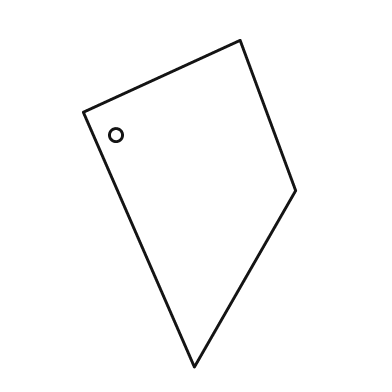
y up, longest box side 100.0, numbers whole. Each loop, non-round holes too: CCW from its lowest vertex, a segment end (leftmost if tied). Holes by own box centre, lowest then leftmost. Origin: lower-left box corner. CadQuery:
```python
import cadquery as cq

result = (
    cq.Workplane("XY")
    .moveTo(34.0, 0.0)
    .lineTo(65.0, 54.0)
    .lineTo(48.0, 100.0)
    .lineTo(0.0, 78.0)
    .close()
    .moveTo(10.0, 71.0)
    .circle(2.0)
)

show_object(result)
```